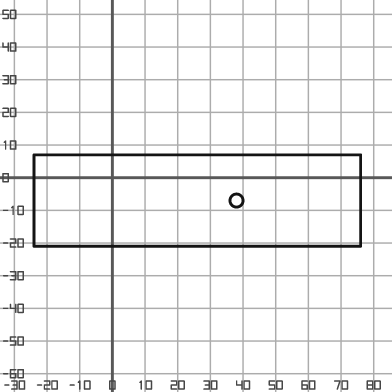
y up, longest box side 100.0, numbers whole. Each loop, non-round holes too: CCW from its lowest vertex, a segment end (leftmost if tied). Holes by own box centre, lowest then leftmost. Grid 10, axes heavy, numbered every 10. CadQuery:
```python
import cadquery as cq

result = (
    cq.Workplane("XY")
    .moveTo(-24.0, -21.0)
    .lineTo(76.0, -21.0)
    .lineTo(76.0, 7.0)
    .lineTo(-24.0, 7.0)
    .close()
    .moveTo(38.0, -7.0)
    .circle(2.0)
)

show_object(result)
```